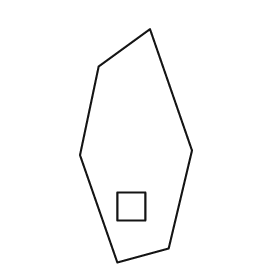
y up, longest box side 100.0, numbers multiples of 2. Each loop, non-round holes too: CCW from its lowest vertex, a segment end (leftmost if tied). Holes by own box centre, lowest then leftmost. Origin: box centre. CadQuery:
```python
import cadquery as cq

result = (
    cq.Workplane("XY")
    .moveTo(-8.0, -50.0)
    .lineTo(14.0, -44.0)
    .lineTo(24.0, -2.0)
    .lineTo(6.0, 50.0)
    .lineTo(-16.0, 34.0)
    .lineTo(-24.0, -4.0)
    .close()
    .moveTo(-8.0, -32.0)
    .lineTo(4.0, -32.0)
    .lineTo(4.0, -20.0)
    .lineTo(-8.0, -20.0)
    .close()
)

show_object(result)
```